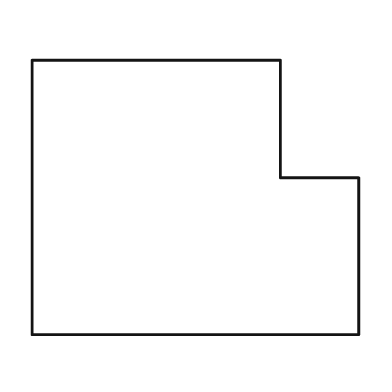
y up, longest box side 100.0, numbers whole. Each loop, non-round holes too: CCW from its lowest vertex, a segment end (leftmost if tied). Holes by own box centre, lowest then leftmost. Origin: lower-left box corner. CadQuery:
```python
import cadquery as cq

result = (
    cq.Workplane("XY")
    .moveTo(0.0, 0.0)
    .lineTo(100.0, 0.0)
    .lineTo(100.0, 48.0)
    .lineTo(76.0, 48.0)
    .lineTo(76.0, 84.0)
    .lineTo(0.0, 84.0)
    .close()
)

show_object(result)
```